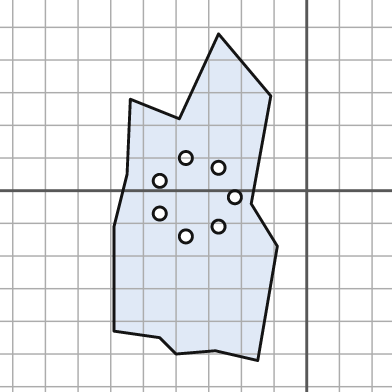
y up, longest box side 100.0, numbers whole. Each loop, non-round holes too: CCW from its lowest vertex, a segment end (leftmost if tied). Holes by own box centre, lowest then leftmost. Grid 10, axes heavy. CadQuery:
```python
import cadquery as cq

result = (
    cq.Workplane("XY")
    .moveTo(-15.0, -52.0)
    .lineTo(-9.0, -17.0)
    .lineTo(-17.0, -4.0)
    .lineTo(-11.0, 29.0)
    .lineTo(-27.0, 48.0)
    .lineTo(-39.0, 22.0)
    .lineTo(-54.0, 28.0)
    .lineTo(-55.0, 5.0)
    .lineTo(-59.0, -11.0)
    .lineTo(-59.0, -43.0)
    .lineTo(-45.0, -45.0)
    .lineTo(-40.0, -50.0)
    .lineTo(-28.0, -49.0)
    .close()
    .moveTo(-37.0, -14.0)
    .circle(2.0)
    .moveTo(-27.0, -11.0)
    .circle(2.0)
    .moveTo(-45.0, -7.0)
    .circle(2.0)
    .moveTo(-22.0, -2.0)
    .circle(2.0)
    .moveTo(-45.0, 3.0)
    .circle(2.0)
    .moveTo(-27.0, 7.0)
    .circle(2.0)
    .moveTo(-37.0, 10.0)
    .circle(2.0)
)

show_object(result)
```